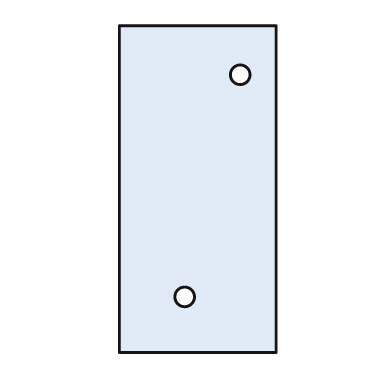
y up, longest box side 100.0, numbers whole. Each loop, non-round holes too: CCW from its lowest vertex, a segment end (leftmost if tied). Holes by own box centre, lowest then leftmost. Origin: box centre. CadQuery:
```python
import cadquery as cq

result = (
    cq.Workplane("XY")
    .moveTo(-24.0, -50.0)
    .lineTo(24.0, -50.0)
    .lineTo(24.0, 50.0)
    .lineTo(-24.0, 50.0)
    .close()
    .moveTo(-4.0, -33.0)
    .circle(3.0)
    .moveTo(13.0, 35.0)
    .circle(3.0)
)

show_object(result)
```